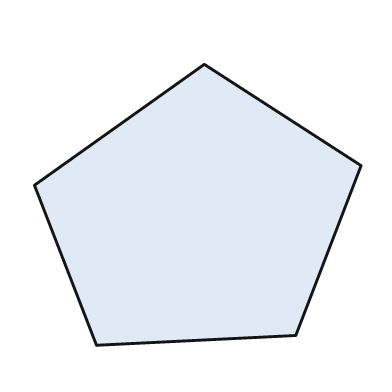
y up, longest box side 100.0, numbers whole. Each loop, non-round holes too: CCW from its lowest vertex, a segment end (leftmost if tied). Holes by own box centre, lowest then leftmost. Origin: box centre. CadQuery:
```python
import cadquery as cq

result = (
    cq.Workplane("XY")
    .moveTo(-31.0, -43.0)
    .lineTo(30.0, -40.0)
    .lineTo(50.0, 12.0)
    .lineTo(2.0, 43.0)
    .lineTo(-50.0, 6.0)
    .close()
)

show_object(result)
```